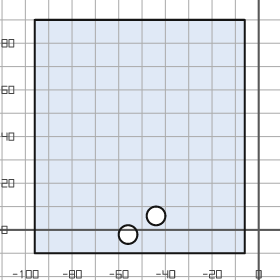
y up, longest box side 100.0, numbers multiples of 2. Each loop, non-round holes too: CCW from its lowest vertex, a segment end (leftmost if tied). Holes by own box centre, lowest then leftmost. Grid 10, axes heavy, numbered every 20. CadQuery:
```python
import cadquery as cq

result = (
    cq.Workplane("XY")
    .moveTo(-96.0, -10.0)
    .lineTo(-6.0, -10.0)
    .lineTo(-6.0, 90.0)
    .lineTo(-96.0, 90.0)
    .close()
    .moveTo(-56.0, -2.0)
    .circle(4.0)
    .moveTo(-44.0, 6.0)
    .circle(4.0)
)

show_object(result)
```